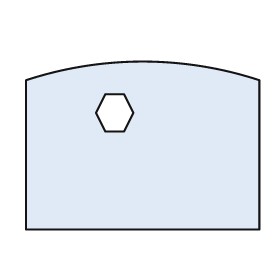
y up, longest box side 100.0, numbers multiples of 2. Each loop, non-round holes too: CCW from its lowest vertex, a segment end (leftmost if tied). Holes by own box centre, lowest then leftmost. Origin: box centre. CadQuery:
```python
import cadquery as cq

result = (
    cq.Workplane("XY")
    .moveTo(-50.0, -36.0)
    .lineTo(50.0, -36.0)
    .lineTo(50.0, 28.0)
    .threePointArc((0.0, 36.0), (-50.0, 28.0))
    .close()
    .moveTo(-16.0, 6.0)
    .lineTo(-8.0, 6.0)
    .lineTo(-4.0, 14.0)
    .lineTo(-8.0, 22.0)
    .lineTo(-16.0, 22.0)
    .lineTo(-20.0, 14.0)
    .close()
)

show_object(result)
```